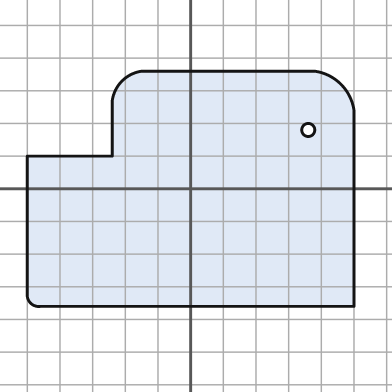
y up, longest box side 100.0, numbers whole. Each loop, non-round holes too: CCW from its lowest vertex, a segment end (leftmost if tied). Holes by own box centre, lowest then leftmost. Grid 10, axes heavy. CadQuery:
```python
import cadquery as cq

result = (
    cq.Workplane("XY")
    .moveTo(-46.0, -36.0)
    .lineTo(50.0, -36.0)
    .lineTo(50.0, 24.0)
    .threePointArc((46.0, 32.0), (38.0, 36.0))
    .lineTo(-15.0, 36.0)
    .threePointArc((-21.0, 33.0), (-24.0, 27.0))
    .lineTo(-24.0, 10.0)
    .lineTo(-50.0, 10.0)
    .lineTo(-50.0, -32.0)
    .threePointArc((-49.0, -35.0), (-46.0, -36.0))
    .close()
    .moveTo(36.0, 18.0)
    .circle(2.0)
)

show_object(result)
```